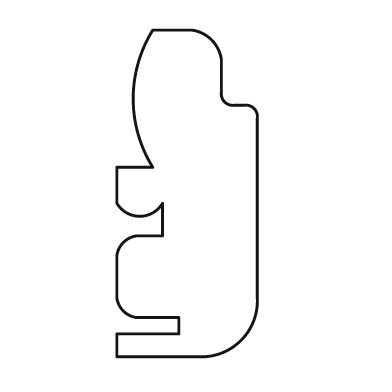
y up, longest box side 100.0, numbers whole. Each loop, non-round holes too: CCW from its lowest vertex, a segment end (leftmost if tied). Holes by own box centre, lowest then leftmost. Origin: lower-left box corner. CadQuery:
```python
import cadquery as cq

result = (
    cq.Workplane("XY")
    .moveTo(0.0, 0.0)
    .lineTo(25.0, 0.0)
    .threePointArc((38.0, 5.0), (43.0, 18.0))
    .lineTo(43.0, 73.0)
    .threePointArc((42.0, 76.0), (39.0, 77.0))
    .lineTo(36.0, 77.0)
    .threePointArc((33.0, 78.0), (32.0, 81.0))
    .lineTo(32.0, 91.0)
    .threePointArc((29.0, 97.0), (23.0, 100.0))
    .lineTo(11.0, 100.0)
    .threePointArc((5.0, 79.0), (11.0, 58.0))
    .lineTo(0.0, 58.0)
    .lineTo(0.0, 47.0)
    .threePointArc((7.0, 43.0), (14.0, 47.0))
    .lineTo(14.0, 37.0)
    .lineTo(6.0, 37.0)
    .threePointArc((2.0, 35.0), (0.0, 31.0))
    .lineTo(0.0, 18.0)
    .threePointArc((2.0, 14.0), (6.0, 12.0))
    .lineTo(19.0, 12.0)
    .lineTo(19.0, 7.0)
    .lineTo(0.0, 7.0)
    .close()
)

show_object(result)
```